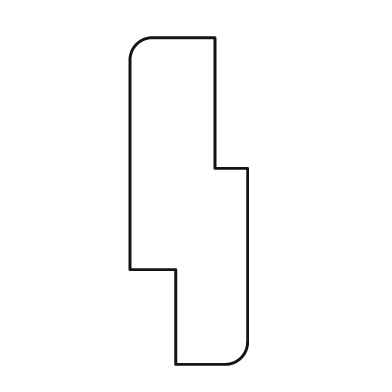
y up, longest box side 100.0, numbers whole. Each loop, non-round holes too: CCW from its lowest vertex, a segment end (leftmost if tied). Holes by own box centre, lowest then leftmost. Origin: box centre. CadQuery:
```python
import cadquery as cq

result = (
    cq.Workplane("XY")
    .moveTo(-4.0, -50.0)
    .lineTo(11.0, -50.0)
    .threePointArc((16.0, -48.0), (18.0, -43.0))
    .lineTo(18.0, 10.0)
    .lineTo(8.0, 10.0)
    .lineTo(8.0, 50.0)
    .lineTo(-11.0, 50.0)
    .threePointArc((-16.0, 48.0), (-18.0, 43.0))
    .lineTo(-18.0, -21.0)
    .lineTo(-4.0, -21.0)
    .close()
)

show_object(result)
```